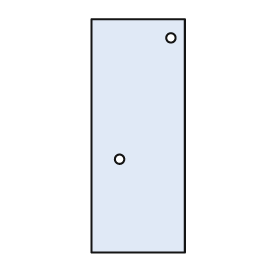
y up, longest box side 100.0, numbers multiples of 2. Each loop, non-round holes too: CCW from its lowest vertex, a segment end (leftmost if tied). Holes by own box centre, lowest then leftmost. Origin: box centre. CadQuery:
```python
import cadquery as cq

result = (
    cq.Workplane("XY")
    .moveTo(-20.0, -50.0)
    .lineTo(20.0, -50.0)
    .lineTo(20.0, 50.0)
    .lineTo(-20.0, 50.0)
    .close()
    .moveTo(-8.0, -10.0)
    .circle(2.0)
    .moveTo(14.0, 42.0)
    .circle(2.0)
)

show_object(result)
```